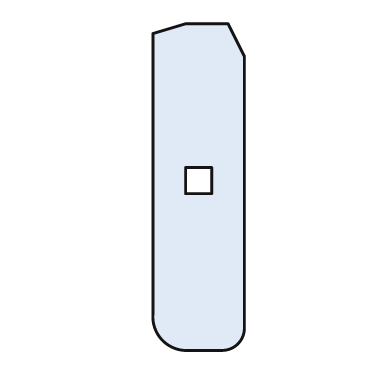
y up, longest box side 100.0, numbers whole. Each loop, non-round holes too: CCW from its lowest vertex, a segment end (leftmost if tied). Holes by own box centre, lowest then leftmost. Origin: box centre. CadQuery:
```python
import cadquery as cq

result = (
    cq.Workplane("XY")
    .moveTo(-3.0, -50.0)
    .lineTo(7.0, -50.0)
    .threePointArc((12.0, -48.0), (14.0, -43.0))
    .lineTo(14.0, 40.0)
    .lineTo(9.0, 50.0)
    .lineTo(-4.0, 50.0)
    .lineTo(-14.0, 47.0)
    .lineTo(-14.0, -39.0)
    .threePointArc((-11.0, -47.0), (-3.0, -50.0))
    .close()
    .moveTo(-4.0, -2.0)
    .lineTo(4.0, -2.0)
    .lineTo(4.0, 6.0)
    .lineTo(-4.0, 6.0)
    .close()
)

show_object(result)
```